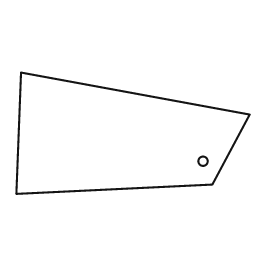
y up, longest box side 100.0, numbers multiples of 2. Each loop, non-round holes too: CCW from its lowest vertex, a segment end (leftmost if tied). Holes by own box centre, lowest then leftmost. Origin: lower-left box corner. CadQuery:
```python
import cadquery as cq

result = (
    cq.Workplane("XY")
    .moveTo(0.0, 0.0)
    .lineTo(84.0, 4.0)
    .lineTo(100.0, 34.0)
    .lineTo(2.0, 52.0)
    .close()
    .moveTo(80.0, 14.0)
    .circle(2.0)
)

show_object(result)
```